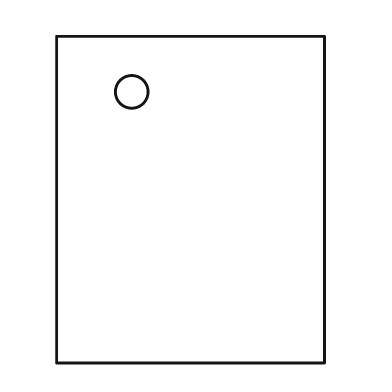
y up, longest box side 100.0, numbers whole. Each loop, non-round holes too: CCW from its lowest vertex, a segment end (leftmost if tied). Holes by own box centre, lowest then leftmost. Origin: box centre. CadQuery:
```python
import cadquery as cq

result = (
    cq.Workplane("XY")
    .moveTo(-41.0, -50.0)
    .lineTo(41.0, -50.0)
    .lineTo(41.0, 50.0)
    .lineTo(-41.0, 50.0)
    .close()
    .moveTo(-18.0, 33.0)
    .circle(5.0)
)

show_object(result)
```